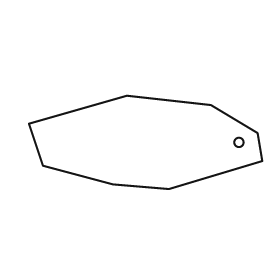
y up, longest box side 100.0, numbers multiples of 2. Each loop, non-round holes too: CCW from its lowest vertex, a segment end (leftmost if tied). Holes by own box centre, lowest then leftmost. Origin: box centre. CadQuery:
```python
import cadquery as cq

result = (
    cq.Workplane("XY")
    .moveTo(10.0, -20.0)
    .lineTo(50.0, -8.0)
    .lineTo(48.0, 4.0)
    .lineTo(28.0, 16.0)
    .lineTo(-8.0, 20.0)
    .lineTo(-50.0, 8.0)
    .lineTo(-44.0, -10.0)
    .lineTo(-14.0, -18.0)
    .close()
    .moveTo(40.0, 0.0)
    .circle(2.0)
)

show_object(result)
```